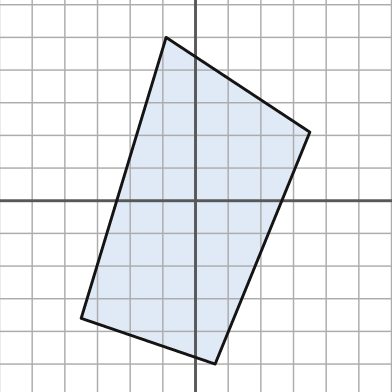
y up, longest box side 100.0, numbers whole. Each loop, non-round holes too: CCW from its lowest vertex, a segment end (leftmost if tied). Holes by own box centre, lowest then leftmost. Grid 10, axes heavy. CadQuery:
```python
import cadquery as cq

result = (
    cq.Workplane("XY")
    .moveTo(6.0, -50.0)
    .lineTo(35.0, 21.0)
    .lineTo(-9.0, 50.0)
    .lineTo(-35.0, -36.0)
    .close()
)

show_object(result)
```